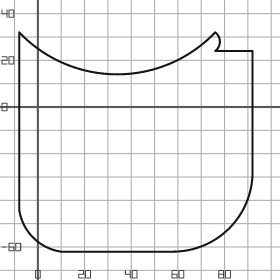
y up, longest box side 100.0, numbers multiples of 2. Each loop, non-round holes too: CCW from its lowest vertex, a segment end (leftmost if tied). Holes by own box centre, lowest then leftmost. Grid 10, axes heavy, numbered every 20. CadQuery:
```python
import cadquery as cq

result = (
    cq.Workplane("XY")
    .moveTo(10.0, -62.0)
    .lineTo(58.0, -62.0)
    .threePointArc((82.0, -52.0), (92.0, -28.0))
    .lineTo(92.0, 24.0)
    .lineTo(76.0, 24.0)
    .threePointArc((78.0, 28.0), (76.0, 32.0))
    .threePointArc((34.0, 14.0), (-8.0, 32.0))
    .lineTo(-8.0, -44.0)
    .threePointArc((-2.0, -56.0), (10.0, -62.0))
    .close()
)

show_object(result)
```